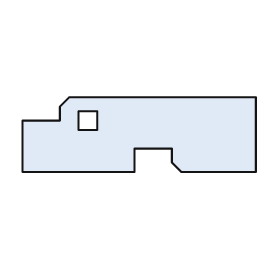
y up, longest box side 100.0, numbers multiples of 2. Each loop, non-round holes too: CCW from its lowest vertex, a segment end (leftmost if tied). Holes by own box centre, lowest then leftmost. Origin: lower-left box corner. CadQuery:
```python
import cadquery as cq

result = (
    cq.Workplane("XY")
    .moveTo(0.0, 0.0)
    .lineTo(48.0, 0.0)
    .lineTo(48.0, 10.0)
    .lineTo(64.0, 10.0)
    .lineTo(64.0, 4.0)
    .lineTo(68.0, 0.0)
    .lineTo(100.0, 0.0)
    .lineTo(100.0, 32.0)
    .lineTo(20.0, 32.0)
    .lineTo(16.0, 28.0)
    .lineTo(16.0, 22.0)
    .lineTo(0.0, 22.0)
    .close()
    .moveTo(24.0, 18.0)
    .lineTo(32.0, 18.0)
    .lineTo(32.0, 26.0)
    .lineTo(24.0, 26.0)
    .close()
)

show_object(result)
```